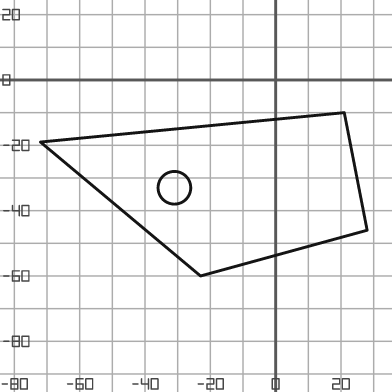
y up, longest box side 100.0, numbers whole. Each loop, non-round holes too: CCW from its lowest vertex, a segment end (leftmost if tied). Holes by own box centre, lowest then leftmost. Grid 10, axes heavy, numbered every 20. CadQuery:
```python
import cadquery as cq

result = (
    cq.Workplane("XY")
    .moveTo(-23.0, -60.0)
    .lineTo(28.0, -46.0)
    .lineTo(21.0, -10.0)
    .lineTo(-72.0, -19.0)
    .close()
    .moveTo(-31.0, -33.0)
    .circle(5.0)
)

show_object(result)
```